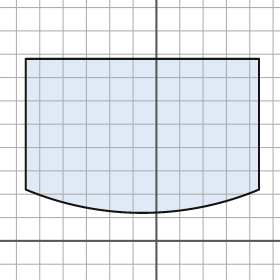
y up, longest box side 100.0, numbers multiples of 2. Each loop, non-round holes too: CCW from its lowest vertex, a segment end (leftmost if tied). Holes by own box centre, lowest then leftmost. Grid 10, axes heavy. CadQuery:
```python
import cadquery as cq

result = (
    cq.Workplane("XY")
    .moveTo(-56.0, 22.0)
    .threePointArc((-6.0, 12.0), (44.0, 22.0))
    .lineTo(44.0, 78.0)
    .lineTo(-56.0, 78.0)
    .close()
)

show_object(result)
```